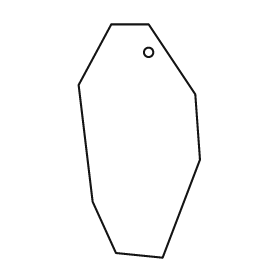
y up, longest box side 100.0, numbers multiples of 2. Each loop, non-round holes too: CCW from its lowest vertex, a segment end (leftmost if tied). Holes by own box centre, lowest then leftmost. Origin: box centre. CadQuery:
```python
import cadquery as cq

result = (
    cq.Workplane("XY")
    .moveTo(10.0, -50.0)
    .lineTo(26.0, -8.0)
    .lineTo(24.0, 20.0)
    .lineTo(4.0, 50.0)
    .lineTo(-12.0, 50.0)
    .lineTo(-26.0, 24.0)
    .lineTo(-20.0, -26.0)
    .lineTo(-10.0, -48.0)
    .close()
    .moveTo(4.0, 38.0)
    .circle(2.0)
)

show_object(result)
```